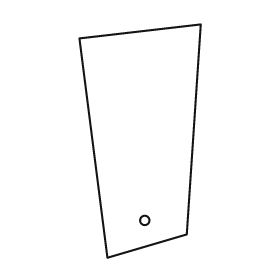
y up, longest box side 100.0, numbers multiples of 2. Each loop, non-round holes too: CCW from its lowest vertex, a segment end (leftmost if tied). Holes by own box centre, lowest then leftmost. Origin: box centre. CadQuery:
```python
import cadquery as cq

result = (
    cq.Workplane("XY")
    .moveTo(-14.0, -50.0)
    .lineTo(20.0, -40.0)
    .lineTo(26.0, 50.0)
    .lineTo(-26.0, 44.0)
    .close()
    .moveTo(2.0, -34.0)
    .circle(2.0)
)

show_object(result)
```